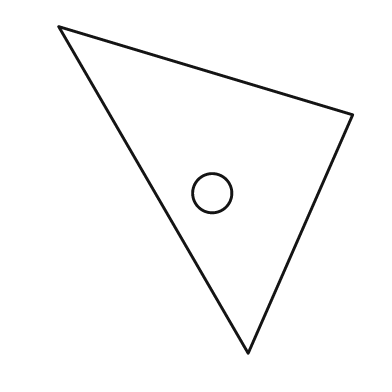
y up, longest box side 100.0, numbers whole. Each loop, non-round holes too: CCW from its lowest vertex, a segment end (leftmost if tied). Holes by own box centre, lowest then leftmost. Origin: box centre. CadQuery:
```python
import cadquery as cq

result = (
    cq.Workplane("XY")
    .moveTo(13.0, -50.0)
    .lineTo(45.0, 23.0)
    .lineTo(-45.0, 50.0)
    .close()
    .moveTo(2.0, -1.0)
    .circle(6.0)
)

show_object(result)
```